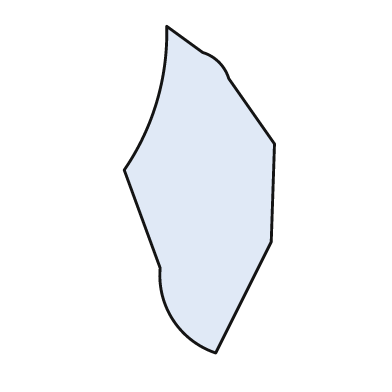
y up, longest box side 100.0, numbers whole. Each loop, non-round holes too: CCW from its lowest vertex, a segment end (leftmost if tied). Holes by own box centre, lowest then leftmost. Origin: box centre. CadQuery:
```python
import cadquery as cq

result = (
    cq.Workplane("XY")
    .moveTo(5.0, -50.0)
    .lineTo(22.0, -16.0)
    .lineTo(23.0, 14.0)
    .lineTo(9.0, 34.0)
    .threePointArc((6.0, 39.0), (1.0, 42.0))
    .lineTo(-10.0, 50.0)
    .threePointArc((-13.0, 27.0), (-23.0, 6.0))
    .lineTo(-12.0, -24.0)
    .threePointArc((-8.0, -40.0), (5.0, -50.0))
    .close()
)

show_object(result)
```